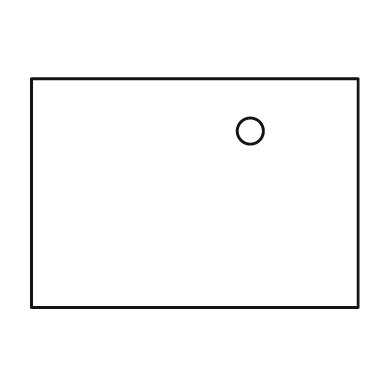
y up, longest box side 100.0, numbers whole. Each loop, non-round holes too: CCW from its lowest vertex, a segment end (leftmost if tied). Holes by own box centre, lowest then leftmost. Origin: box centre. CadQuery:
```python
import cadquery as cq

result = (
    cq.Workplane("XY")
    .moveTo(-50.0, -35.0)
    .lineTo(50.0, -35.0)
    .lineTo(50.0, 35.0)
    .lineTo(-50.0, 35.0)
    .close()
    .moveTo(17.0, 19.0)
    .circle(4.0)
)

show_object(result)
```